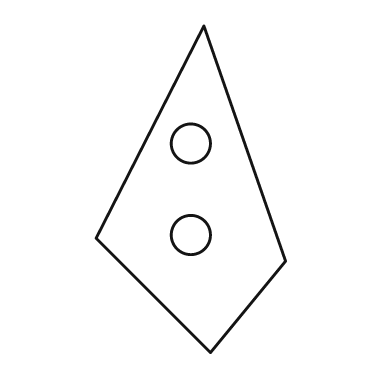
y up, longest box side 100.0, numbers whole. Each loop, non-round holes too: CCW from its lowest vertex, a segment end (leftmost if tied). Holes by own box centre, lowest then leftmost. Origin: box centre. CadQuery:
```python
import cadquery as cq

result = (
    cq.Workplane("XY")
    .moveTo(6.0, -50.0)
    .lineTo(29.0, -22.0)
    .lineTo(4.0, 50.0)
    .lineTo(-29.0, -15.0)
    .close()
    .moveTo(0.0, -14.0)
    .circle(6.0)
    .moveTo(0.0, 14.0)
    .circle(6.0)
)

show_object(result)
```